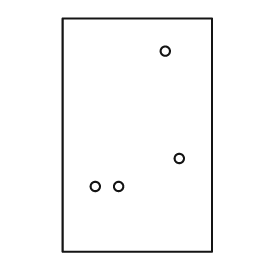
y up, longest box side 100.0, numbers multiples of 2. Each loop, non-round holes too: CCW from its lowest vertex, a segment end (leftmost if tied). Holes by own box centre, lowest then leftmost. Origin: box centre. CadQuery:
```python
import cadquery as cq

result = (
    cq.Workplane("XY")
    .moveTo(-32.0, -50.0)
    .lineTo(32.0, -50.0)
    .lineTo(32.0, 50.0)
    .lineTo(-32.0, 50.0)
    .close()
    .moveTo(-18.0, -22.0)
    .circle(2.0)
    .moveTo(-8.0, -22.0)
    .circle(2.0)
    .moveTo(18.0, -10.0)
    .circle(2.0)
    .moveTo(12.0, 36.0)
    .circle(2.0)
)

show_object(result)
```